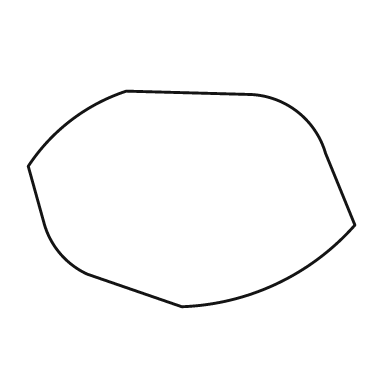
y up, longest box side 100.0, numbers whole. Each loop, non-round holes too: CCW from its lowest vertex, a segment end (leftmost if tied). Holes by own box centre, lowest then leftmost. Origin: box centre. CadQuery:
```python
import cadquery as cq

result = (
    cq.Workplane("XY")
    .moveTo(-3.0, -33.0)
    .threePointArc((26.0, -26.0), (50.0, -8.0))
    .lineTo(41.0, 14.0)
    .threePointArc((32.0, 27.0), (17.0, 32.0))
    .lineTo(-20.0, 33.0)
    .threePointArc((-37.0, 24.0), (-50.0, 10.0))
    .lineTo(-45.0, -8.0)
    .threePointArc((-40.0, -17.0), (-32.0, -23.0))
    .close()
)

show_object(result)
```